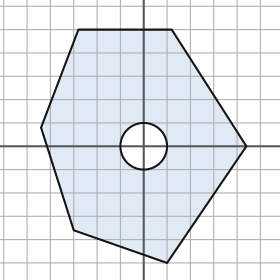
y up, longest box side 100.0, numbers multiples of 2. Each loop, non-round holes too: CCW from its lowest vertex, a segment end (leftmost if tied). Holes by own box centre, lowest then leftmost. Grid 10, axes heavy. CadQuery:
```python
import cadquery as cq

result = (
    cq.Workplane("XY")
    .moveTo(10.0, -50.0)
    .lineTo(44.0, 0.0)
    .lineTo(12.0, 50.0)
    .lineTo(-28.0, 50.0)
    .lineTo(-44.0, 8.0)
    .lineTo(-30.0, -36.0)
    .close()
    .moveTo(0.0, 0.0)
    .circle(10.0)
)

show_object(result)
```